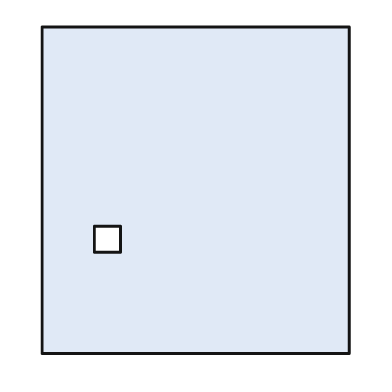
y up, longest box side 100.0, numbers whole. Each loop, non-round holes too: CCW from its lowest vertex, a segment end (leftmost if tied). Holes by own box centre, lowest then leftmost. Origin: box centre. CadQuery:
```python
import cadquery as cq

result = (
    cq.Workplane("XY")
    .moveTo(-47.0, -50.0)
    .lineTo(47.0, -50.0)
    .lineTo(47.0, 50.0)
    .lineTo(-47.0, 50.0)
    .close()
    .moveTo(-31.0, -19.0)
    .lineTo(-23.0, -19.0)
    .lineTo(-23.0, -11.0)
    .lineTo(-31.0, -11.0)
    .close()
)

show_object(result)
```